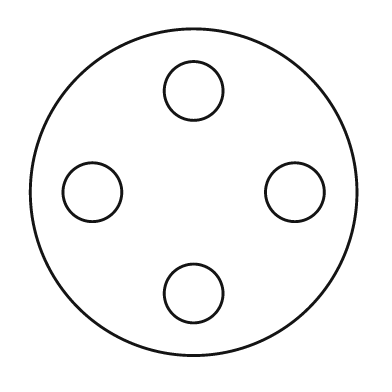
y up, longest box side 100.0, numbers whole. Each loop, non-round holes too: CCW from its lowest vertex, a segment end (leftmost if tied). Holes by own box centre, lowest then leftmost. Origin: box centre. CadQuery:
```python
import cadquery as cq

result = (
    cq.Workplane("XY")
    .moveTo(0.0, 0.0)
    .circle(50.0)
    .moveTo(0.0, -31.0)
    .circle(9.0)
    .moveTo(-31.0, 0.0)
    .circle(9.0)
    .moveTo(31.0, 0.0)
    .circle(9.0)
    .moveTo(0.0, 31.0)
    .circle(9.0)
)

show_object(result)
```